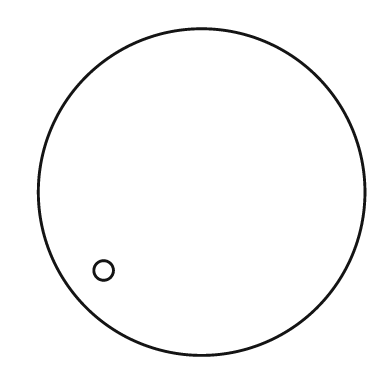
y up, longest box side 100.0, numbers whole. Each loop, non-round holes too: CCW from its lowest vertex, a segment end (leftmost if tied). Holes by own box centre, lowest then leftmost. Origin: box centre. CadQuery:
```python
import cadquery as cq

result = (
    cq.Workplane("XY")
    .moveTo(0.0, 0.0)
    .circle(50.0)
    .moveTo(-30.0, -24.0)
    .circle(3.0)
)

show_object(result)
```